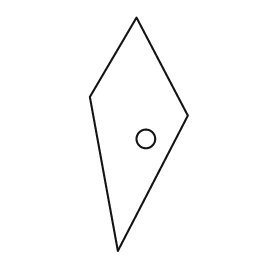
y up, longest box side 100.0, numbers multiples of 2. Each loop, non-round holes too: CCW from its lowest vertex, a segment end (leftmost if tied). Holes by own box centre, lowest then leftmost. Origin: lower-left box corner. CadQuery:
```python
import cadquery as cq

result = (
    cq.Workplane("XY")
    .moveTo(12.0, 0.0)
    .lineTo(42.0, 58.0)
    .lineTo(20.0, 100.0)
    .lineTo(0.0, 66.0)
    .close()
    .moveTo(24.0, 48.0)
    .circle(4.0)
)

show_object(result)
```